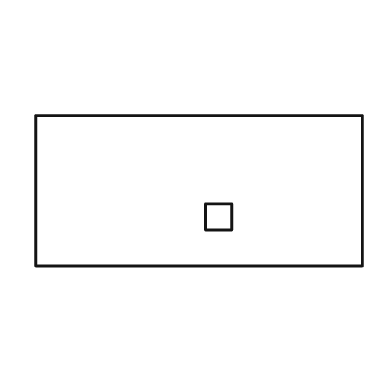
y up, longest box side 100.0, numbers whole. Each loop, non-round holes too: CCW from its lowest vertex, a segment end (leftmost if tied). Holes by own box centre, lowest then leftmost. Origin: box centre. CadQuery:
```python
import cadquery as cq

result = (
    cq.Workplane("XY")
    .moveTo(-50.0, -23.0)
    .lineTo(50.0, -23.0)
    .lineTo(50.0, 23.0)
    .lineTo(-50.0, 23.0)
    .close()
    .moveTo(2.0, -12.0)
    .lineTo(10.0, -12.0)
    .lineTo(10.0, -4.0)
    .lineTo(2.0, -4.0)
    .close()
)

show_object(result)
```